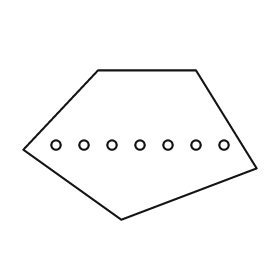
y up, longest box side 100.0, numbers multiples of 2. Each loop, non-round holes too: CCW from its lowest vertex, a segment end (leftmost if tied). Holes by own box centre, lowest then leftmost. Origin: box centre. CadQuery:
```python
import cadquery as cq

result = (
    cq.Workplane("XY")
    .moveTo(-8.0, -32.0)
    .lineTo(50.0, -10.0)
    .lineTo(24.0, 32.0)
    .lineTo(-18.0, 32.0)
    .lineTo(-50.0, -2.0)
    .close()
    .moveTo(-36.0, 0.0)
    .circle(2.0)
    .moveTo(-24.0, 0.0)
    .circle(2.0)
    .moveTo(-12.0, 0.0)
    .circle(2.0)
    .moveTo(0.0, 0.0)
    .circle(2.0)
    .moveTo(12.0, 0.0)
    .circle(2.0)
    .moveTo(24.0, 0.0)
    .circle(2.0)
    .moveTo(36.0, 0.0)
    .circle(2.0)
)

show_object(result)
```